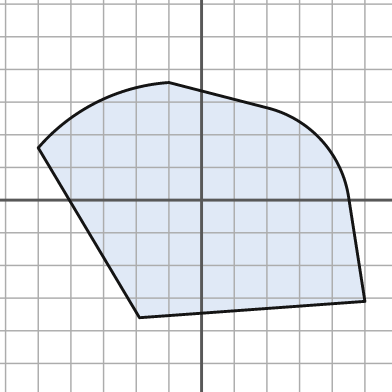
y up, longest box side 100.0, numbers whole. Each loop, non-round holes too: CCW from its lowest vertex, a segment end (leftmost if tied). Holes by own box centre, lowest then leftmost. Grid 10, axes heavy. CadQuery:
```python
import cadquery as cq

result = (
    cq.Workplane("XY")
    .moveTo(-19.0, -36.0)
    .lineTo(50.0, -31.0)
    .lineTo(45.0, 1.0)
    .threePointArc((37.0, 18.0), (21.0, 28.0))
    .lineTo(-10.0, 36.0)
    .threePointArc((-32.0, 30.0), (-50.0, 16.0))
    .close()
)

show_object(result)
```